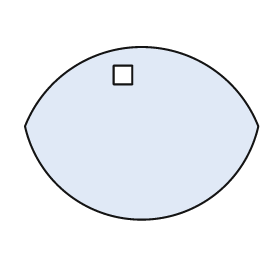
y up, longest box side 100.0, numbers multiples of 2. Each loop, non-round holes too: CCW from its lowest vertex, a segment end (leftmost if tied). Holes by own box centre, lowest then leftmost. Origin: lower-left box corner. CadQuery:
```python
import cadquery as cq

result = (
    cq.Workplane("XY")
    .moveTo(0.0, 40.0)
    .threePointArc((50.0, 0.0), (100.0, 40.0))
    .threePointArc((50.0, 74.0), (0.0, 40.0))
    .close()
    .moveTo(38.0, 58.0)
    .lineTo(46.0, 58.0)
    .lineTo(46.0, 66.0)
    .lineTo(38.0, 66.0)
    .close()
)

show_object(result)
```